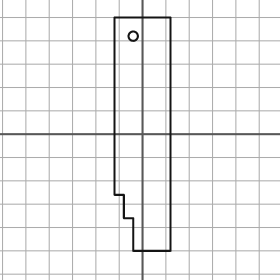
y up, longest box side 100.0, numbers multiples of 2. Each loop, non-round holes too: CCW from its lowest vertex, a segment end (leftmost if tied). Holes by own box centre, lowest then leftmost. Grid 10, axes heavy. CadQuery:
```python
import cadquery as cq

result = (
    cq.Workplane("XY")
    .moveTo(-4.0, -50.0)
    .lineTo(12.0, -50.0)
    .lineTo(12.0, 50.0)
    .lineTo(-12.0, 50.0)
    .lineTo(-12.0, -26.0)
    .lineTo(-8.0, -26.0)
    .lineTo(-8.0, -36.0)
    .lineTo(-4.0, -36.0)
    .close()
    .moveTo(-4.0, 42.0)
    .circle(2.0)
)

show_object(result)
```